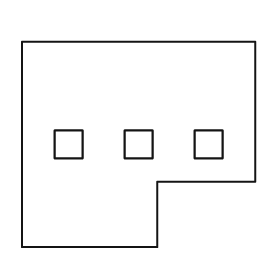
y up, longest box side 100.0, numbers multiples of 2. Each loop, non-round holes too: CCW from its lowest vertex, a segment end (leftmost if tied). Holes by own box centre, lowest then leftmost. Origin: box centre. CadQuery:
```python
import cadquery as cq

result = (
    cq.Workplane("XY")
    .moveTo(-50.0, -44.0)
    .lineTo(8.0, -44.0)
    .lineTo(8.0, -16.0)
    .lineTo(50.0, -16.0)
    .lineTo(50.0, 44.0)
    .lineTo(-50.0, 44.0)
    .close()
    .moveTo(-36.0, -6.0)
    .lineTo(-24.0, -6.0)
    .lineTo(-24.0, 6.0)
    .lineTo(-36.0, 6.0)
    .close()
    .moveTo(-6.0, -6.0)
    .lineTo(6.0, -6.0)
    .lineTo(6.0, 6.0)
    .lineTo(-6.0, 6.0)
    .close()
    .moveTo(24.0, -6.0)
    .lineTo(36.0, -6.0)
    .lineTo(36.0, 6.0)
    .lineTo(24.0, 6.0)
    .close()
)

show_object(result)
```